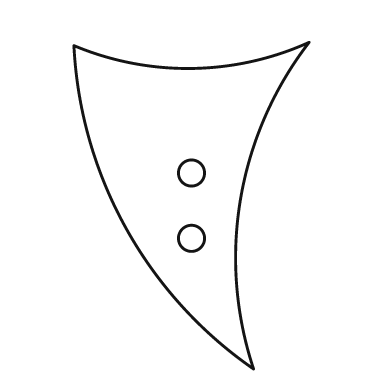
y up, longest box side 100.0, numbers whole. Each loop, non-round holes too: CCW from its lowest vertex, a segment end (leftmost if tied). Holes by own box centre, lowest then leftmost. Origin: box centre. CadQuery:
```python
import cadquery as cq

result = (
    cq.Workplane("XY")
    .moveTo(19.0, -50.0)
    .threePointArc((15.0, 2.0), (36.0, 50.0))
    .threePointArc((0.0, 42.0), (-36.0, 49.0))
    .threePointArc((-20.0, -7.0), (19.0, -50.0))
    .close()
    .moveTo(0.0, -10.0)
    .circle(4.0)
    .moveTo(0.0, 10.0)
    .circle(4.0)
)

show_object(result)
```